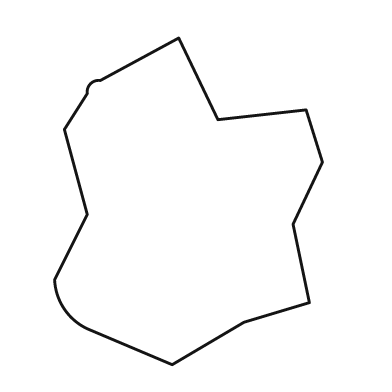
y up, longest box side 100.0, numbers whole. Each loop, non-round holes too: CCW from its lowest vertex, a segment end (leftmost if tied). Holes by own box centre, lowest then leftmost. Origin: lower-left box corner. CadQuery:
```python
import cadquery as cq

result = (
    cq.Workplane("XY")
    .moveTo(36.0, 0.0)
    .lineTo(58.0, 13.0)
    .lineTo(78.0, 19.0)
    .lineTo(73.0, 43.0)
    .lineTo(82.0, 62.0)
    .lineTo(77.0, 78.0)
    .lineTo(50.0, 75.0)
    .lineTo(38.0, 100.0)
    .lineTo(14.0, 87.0)
    .threePointArc((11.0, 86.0), (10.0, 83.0))
    .lineTo(3.0, 72.0)
    .lineTo(10.0, 46.0)
    .lineTo(0.0, 26.0)
    .threePointArc((3.0, 17.0), (10.0, 11.0))
    .close()
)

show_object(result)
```